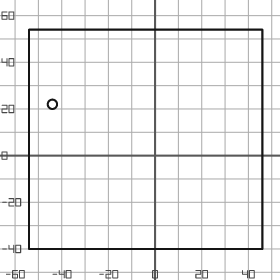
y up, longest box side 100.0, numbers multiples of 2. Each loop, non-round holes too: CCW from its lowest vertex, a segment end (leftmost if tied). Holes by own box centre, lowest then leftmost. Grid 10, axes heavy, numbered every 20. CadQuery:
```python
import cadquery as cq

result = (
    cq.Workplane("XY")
    .moveTo(-54.0, -40.0)
    .lineTo(46.0, -40.0)
    .lineTo(46.0, 54.0)
    .lineTo(-54.0, 54.0)
    .close()
    .moveTo(-44.0, 22.0)
    .circle(2.0)
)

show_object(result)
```